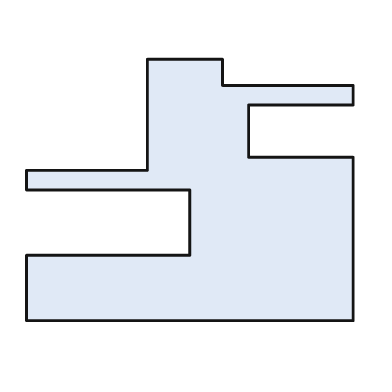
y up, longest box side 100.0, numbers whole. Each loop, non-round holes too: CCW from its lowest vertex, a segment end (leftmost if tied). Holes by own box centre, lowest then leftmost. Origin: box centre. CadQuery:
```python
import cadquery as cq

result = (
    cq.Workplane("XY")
    .moveTo(-50.0, -40.0)
    .lineTo(50.0, -40.0)
    .lineTo(50.0, 10.0)
    .lineTo(18.0, 10.0)
    .lineTo(18.0, 26.0)
    .lineTo(50.0, 26.0)
    .lineTo(50.0, 32.0)
    .lineTo(10.0, 32.0)
    .lineTo(10.0, 40.0)
    .lineTo(-13.0, 40.0)
    .lineTo(-13.0, 6.0)
    .lineTo(-50.0, 6.0)
    .lineTo(-50.0, 0.0)
    .lineTo(0.0, 0.0)
    .lineTo(0.0, -20.0)
    .lineTo(-50.0, -20.0)
    .close()
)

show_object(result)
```